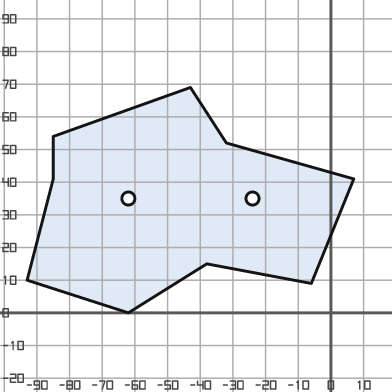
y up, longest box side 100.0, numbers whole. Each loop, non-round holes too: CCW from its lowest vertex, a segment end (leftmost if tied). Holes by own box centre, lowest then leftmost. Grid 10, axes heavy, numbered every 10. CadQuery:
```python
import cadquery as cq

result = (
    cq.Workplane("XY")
    .moveTo(-62.0, 0.0)
    .lineTo(-38.0, 15.0)
    .lineTo(-6.0, 9.0)
    .lineTo(7.0, 41.0)
    .lineTo(-32.0, 52.0)
    .lineTo(-43.0, 69.0)
    .lineTo(-85.0, 54.0)
    .lineTo(-85.0, 41.0)
    .lineTo(-93.0, 10.0)
    .close()
    .moveTo(-62.0, 35.0)
    .circle(2.0)
    .moveTo(-24.0, 35.0)
    .circle(2.0)
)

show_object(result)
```